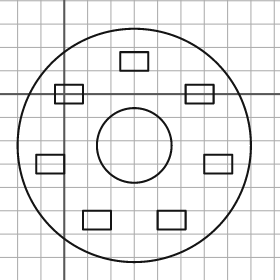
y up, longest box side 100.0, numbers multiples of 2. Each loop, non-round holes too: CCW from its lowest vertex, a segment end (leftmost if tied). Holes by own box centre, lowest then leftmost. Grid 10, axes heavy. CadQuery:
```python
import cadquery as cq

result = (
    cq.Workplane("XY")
    .moveTo(30.0, -22.0)
    .circle(50.0)
    .moveTo(8.0, -58.0)
    .lineTo(20.0, -58.0)
    .lineTo(20.0, -50.0)
    .lineTo(8.0, -50.0)
    .close()
    .moveTo(40.0, -58.0)
    .lineTo(52.0, -58.0)
    .lineTo(52.0, -50.0)
    .lineTo(40.0, -50.0)
    .close()
    .moveTo(-12.0, -34.0)
    .lineTo(0.0, -34.0)
    .lineTo(0.0, -26.0)
    .lineTo(-12.0, -26.0)
    .close()
    .moveTo(60.0, -34.0)
    .lineTo(72.0, -34.0)
    .lineTo(72.0, -26.0)
    .lineTo(60.0, -26.0)
    .close()
    .moveTo(30.0, -22.0)
    .circle(16.0)
    .moveTo(-4.0, -4.0)
    .lineTo(8.0, -4.0)
    .lineTo(8.0, 4.0)
    .lineTo(-4.0, 4.0)
    .close()
    .moveTo(52.0, -4.0)
    .lineTo(64.0, -4.0)
    .lineTo(64.0, 4.0)
    .lineTo(52.0, 4.0)
    .close()
    .moveTo(24.0, 10.0)
    .lineTo(36.0, 10.0)
    .lineTo(36.0, 18.0)
    .lineTo(24.0, 18.0)
    .close()
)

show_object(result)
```